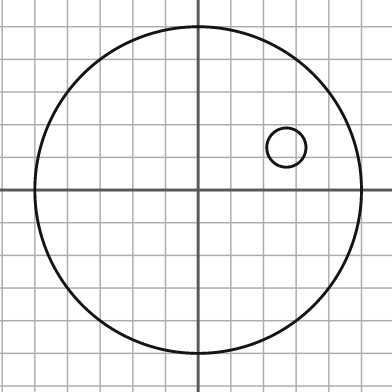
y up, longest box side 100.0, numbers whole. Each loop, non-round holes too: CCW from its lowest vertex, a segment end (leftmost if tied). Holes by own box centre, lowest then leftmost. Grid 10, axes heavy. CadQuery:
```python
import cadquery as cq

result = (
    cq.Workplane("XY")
    .moveTo(0.0, 0.0)
    .circle(50.0)
    .moveTo(27.0, 13.0)
    .circle(6.0)
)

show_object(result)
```